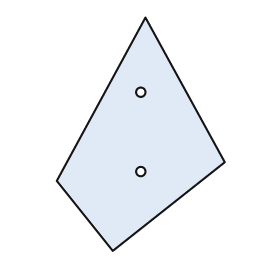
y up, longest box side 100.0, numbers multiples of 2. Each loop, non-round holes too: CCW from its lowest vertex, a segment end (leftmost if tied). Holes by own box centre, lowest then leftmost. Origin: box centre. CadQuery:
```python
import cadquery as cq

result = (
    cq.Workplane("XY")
    .moveTo(-12.0, -50.0)
    .lineTo(36.0, -12.0)
    .lineTo(2.0, 50.0)
    .lineTo(-36.0, -20.0)
    .close()
    .moveTo(0.0, -16.0)
    .circle(2.0)
    .moveTo(0.0, 18.0)
    .circle(2.0)
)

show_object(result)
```